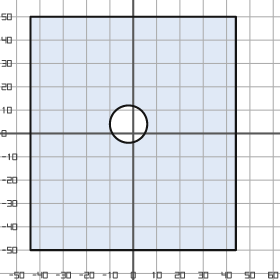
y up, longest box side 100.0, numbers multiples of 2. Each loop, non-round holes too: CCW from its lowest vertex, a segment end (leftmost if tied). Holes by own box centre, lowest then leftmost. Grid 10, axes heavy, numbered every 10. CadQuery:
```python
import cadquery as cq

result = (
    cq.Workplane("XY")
    .moveTo(-44.0, -50.0)
    .lineTo(44.0, -50.0)
    .lineTo(44.0, 50.0)
    .lineTo(-44.0, 50.0)
    .close()
    .moveTo(-2.0, 4.0)
    .circle(8.0)
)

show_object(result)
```